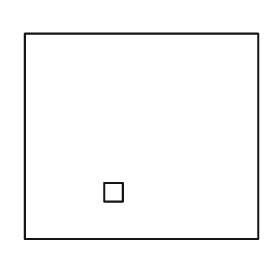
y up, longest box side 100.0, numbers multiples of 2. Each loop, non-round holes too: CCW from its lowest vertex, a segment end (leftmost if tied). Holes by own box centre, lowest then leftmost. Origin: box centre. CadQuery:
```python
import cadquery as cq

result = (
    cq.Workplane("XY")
    .moveTo(-50.0, -44.0)
    .lineTo(50.0, -44.0)
    .lineTo(50.0, 44.0)
    .lineTo(-50.0, 44.0)
    .close()
    .moveTo(-16.0, -28.0)
    .lineTo(-8.0, -28.0)
    .lineTo(-8.0, -20.0)
    .lineTo(-16.0, -20.0)
    .close()
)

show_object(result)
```